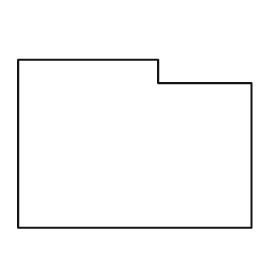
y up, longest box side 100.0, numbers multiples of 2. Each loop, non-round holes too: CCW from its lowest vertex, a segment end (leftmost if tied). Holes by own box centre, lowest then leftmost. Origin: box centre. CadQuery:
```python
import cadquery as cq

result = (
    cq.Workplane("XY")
    .moveTo(-50.0, -36.0)
    .lineTo(50.0, -36.0)
    .lineTo(50.0, 26.0)
    .lineTo(10.0, 26.0)
    .lineTo(10.0, 36.0)
    .lineTo(-50.0, 36.0)
    .close()
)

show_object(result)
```